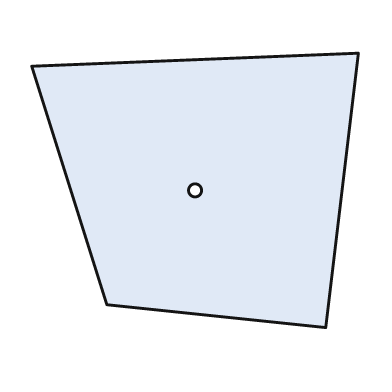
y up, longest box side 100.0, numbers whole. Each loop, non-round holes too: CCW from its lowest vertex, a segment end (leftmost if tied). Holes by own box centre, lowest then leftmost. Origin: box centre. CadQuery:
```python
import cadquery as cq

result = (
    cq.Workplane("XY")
    .moveTo(40.0, -42.0)
    .lineTo(50.0, 42.0)
    .lineTo(-50.0, 38.0)
    .lineTo(-27.0, -35.0)
    .close()
    .moveTo(0.0, 0.0)
    .circle(2.0)
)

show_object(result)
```